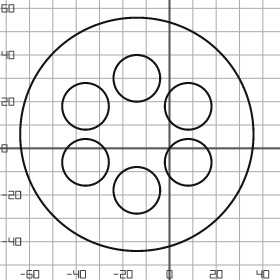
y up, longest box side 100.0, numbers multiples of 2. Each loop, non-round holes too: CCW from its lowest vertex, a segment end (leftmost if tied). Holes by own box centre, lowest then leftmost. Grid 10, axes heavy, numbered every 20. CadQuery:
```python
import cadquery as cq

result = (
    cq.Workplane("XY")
    .moveTo(-14.0, 6.0)
    .circle(50.0)
    .moveTo(-14.0, -18.0)
    .circle(10.0)
    .moveTo(-36.0, -6.0)
    .circle(10.0)
    .moveTo(8.0, -6.0)
    .circle(10.0)
    .moveTo(-36.0, 18.0)
    .circle(10.0)
    .moveTo(8.0, 18.0)
    .circle(10.0)
    .moveTo(-14.0, 30.0)
    .circle(10.0)
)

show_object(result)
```